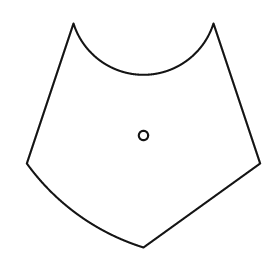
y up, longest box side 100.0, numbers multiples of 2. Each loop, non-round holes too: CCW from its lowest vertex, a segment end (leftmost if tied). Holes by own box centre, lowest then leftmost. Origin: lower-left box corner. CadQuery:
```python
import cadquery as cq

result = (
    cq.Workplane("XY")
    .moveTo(50.0, 0.0)
    .lineTo(100.0, 36.0)
    .lineTo(80.0, 96.0)
    .threePointArc((50.0, 74.0), (20.0, 96.0))
    .lineTo(0.0, 36.0)
    .threePointArc((22.0, 14.0), (50.0, 0.0))
    .close()
    .moveTo(50.0, 48.0)
    .circle(2.0)
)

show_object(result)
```